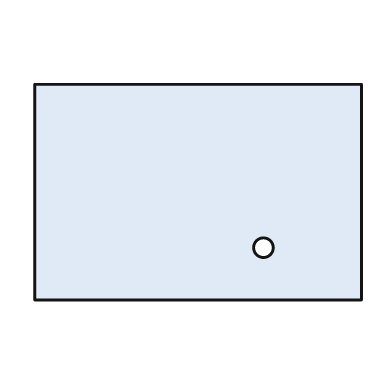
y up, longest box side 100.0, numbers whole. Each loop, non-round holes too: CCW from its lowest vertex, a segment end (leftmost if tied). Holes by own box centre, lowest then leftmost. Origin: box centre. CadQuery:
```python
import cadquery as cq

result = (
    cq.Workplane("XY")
    .moveTo(-50.0, -33.0)
    .lineTo(50.0, -33.0)
    .lineTo(50.0, 33.0)
    .lineTo(-50.0, 33.0)
    .close()
    .moveTo(20.0, -17.0)
    .circle(3.0)
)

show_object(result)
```